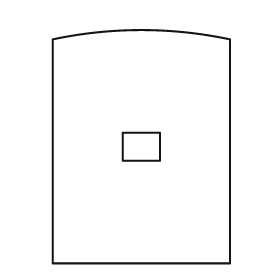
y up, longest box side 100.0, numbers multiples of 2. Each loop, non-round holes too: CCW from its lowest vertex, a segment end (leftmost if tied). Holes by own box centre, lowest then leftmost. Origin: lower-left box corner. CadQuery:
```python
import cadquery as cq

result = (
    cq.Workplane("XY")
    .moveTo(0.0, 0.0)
    .lineTo(76.0, 0.0)
    .lineTo(76.0, 96.0)
    .threePointArc((38.0, 100.0), (0.0, 96.0))
    .close()
    .moveTo(30.0, 44.0)
    .lineTo(46.0, 44.0)
    .lineTo(46.0, 56.0)
    .lineTo(30.0, 56.0)
    .close()
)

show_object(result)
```